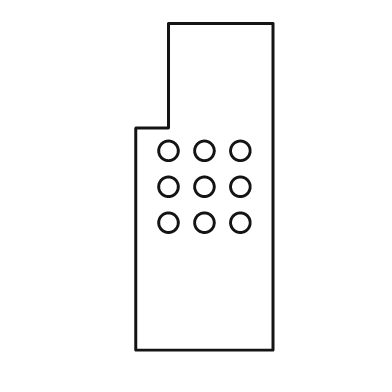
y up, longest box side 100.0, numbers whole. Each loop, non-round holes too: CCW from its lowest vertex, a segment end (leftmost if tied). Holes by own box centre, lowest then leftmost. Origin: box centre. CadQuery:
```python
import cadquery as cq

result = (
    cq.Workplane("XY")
    .moveTo(-21.0, -50.0)
    .lineTo(21.0, -50.0)
    .lineTo(21.0, 50.0)
    .lineTo(-11.0, 50.0)
    .lineTo(-11.0, 18.0)
    .lineTo(-21.0, 18.0)
    .close()
    .moveTo(-11.0, -11.0)
    .circle(3.0)
    .moveTo(0.0, -11.0)
    .circle(3.0)
    .moveTo(11.0, -11.0)
    .circle(3.0)
    .moveTo(-11.0, 0.0)
    .circle(3.0)
    .moveTo(0.0, 0.0)
    .circle(3.0)
    .moveTo(11.0, 0.0)
    .circle(3.0)
    .moveTo(-11.0, 11.0)
    .circle(3.0)
    .moveTo(0.0, 11.0)
    .circle(3.0)
    .moveTo(11.0, 11.0)
    .circle(3.0)
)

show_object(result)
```